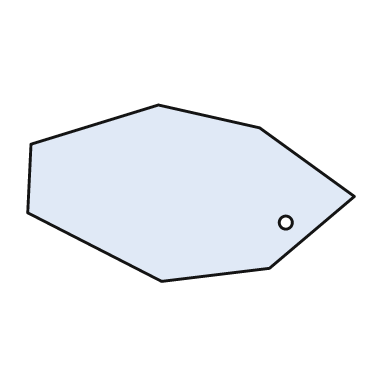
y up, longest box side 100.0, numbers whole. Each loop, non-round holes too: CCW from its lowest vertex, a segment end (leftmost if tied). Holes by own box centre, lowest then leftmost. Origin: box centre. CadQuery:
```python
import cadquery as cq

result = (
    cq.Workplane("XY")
    .moveTo(-9.0, -27.0)
    .lineTo(24.0, -23.0)
    .lineTo(50.0, -1.0)
    .lineTo(21.0, 20.0)
    .lineTo(-10.0, 27.0)
    .lineTo(-49.0, 15.0)
    .lineTo(-50.0, -6.0)
    .close()
    .moveTo(29.0, -9.0)
    .circle(2.0)
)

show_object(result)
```